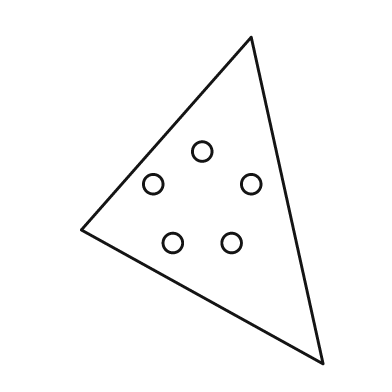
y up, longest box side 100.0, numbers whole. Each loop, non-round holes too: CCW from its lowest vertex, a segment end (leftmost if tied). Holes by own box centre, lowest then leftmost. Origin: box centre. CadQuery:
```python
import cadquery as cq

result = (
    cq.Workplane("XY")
    .moveTo(37.0, -50.0)
    .lineTo(15.0, 50.0)
    .lineTo(-37.0, -9.0)
    .close()
    .moveTo(-9.0, -13.0)
    .circle(3.0)
    .moveTo(9.0, -13.0)
    .circle(3.0)
    .moveTo(-15.0, 5.0)
    .circle(3.0)
    .moveTo(15.0, 5.0)
    .circle(3.0)
    .moveTo(0.0, 15.0)
    .circle(3.0)
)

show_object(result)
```